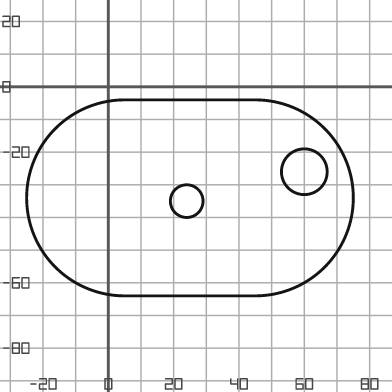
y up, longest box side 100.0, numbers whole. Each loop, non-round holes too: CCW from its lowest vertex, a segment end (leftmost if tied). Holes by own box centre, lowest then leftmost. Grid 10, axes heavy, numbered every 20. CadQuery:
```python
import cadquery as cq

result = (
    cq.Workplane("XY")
    .moveTo(5.0, -64.0)
    .lineTo(45.0, -64.0)
    .threePointArc((75.0, -34.0), (45.0, -4.0))
    .lineTo(5.0, -4.0)
    .threePointArc((-25.0, -34.0), (5.0, -64.0))
    .close()
    .moveTo(24.0, -35.0)
    .circle(5.0)
    .moveTo(60.0, -26.0)
    .circle(7.0)
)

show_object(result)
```